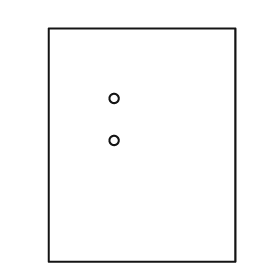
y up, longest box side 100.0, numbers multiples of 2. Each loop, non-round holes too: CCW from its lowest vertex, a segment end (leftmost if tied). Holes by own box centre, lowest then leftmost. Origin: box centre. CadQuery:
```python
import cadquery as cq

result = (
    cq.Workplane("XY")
    .moveTo(-40.0, -50.0)
    .lineTo(40.0, -50.0)
    .lineTo(40.0, 50.0)
    .lineTo(-40.0, 50.0)
    .close()
    .moveTo(-12.0, 2.0)
    .circle(2.0)
    .moveTo(-12.0, 20.0)
    .circle(2.0)
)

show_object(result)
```